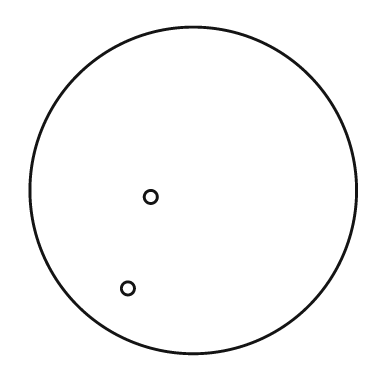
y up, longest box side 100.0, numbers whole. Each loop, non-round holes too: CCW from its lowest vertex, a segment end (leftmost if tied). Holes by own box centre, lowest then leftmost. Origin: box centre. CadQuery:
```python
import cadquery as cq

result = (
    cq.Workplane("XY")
    .moveTo(0.0, 0.0)
    .circle(50.0)
    .moveTo(-20.0, -30.0)
    .circle(2.0)
    .moveTo(-13.0, -2.0)
    .circle(2.0)
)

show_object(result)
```